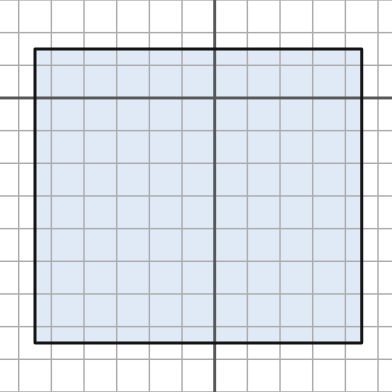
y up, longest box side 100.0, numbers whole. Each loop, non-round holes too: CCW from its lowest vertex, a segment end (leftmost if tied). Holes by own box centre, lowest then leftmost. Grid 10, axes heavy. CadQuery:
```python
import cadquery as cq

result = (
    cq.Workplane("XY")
    .moveTo(-55.0, -75.0)
    .lineTo(45.0, -75.0)
    .lineTo(45.0, 15.0)
    .lineTo(-55.0, 15.0)
    .close()
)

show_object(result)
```